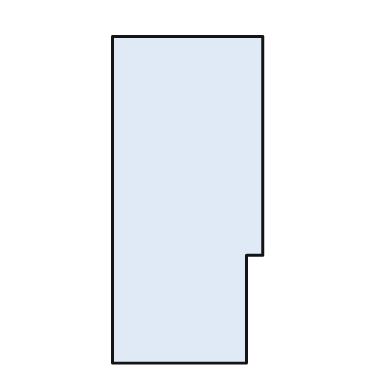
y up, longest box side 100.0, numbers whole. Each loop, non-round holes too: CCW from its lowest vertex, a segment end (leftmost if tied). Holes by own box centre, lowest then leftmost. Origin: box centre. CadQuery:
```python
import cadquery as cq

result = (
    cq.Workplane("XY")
    .moveTo(-23.0, -50.0)
    .lineTo(18.0, -50.0)
    .lineTo(18.0, -17.0)
    .lineTo(23.0, -17.0)
    .lineTo(23.0, 50.0)
    .lineTo(-23.0, 50.0)
    .close()
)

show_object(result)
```